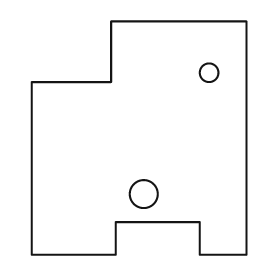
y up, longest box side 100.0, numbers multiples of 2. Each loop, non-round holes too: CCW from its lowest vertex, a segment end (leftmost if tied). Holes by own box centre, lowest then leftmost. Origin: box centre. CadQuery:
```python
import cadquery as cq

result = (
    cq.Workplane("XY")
    .moveTo(-46.0, -50.0)
    .lineTo(-10.0, -50.0)
    .lineTo(-10.0, -36.0)
    .lineTo(26.0, -36.0)
    .lineTo(26.0, -50.0)
    .lineTo(46.0, -50.0)
    .lineTo(46.0, 50.0)
    .lineTo(-12.0, 50.0)
    .lineTo(-12.0, 24.0)
    .lineTo(-46.0, 24.0)
    .close()
    .moveTo(2.0, -24.0)
    .circle(6.0)
    .moveTo(30.0, 28.0)
    .circle(4.0)
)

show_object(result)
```